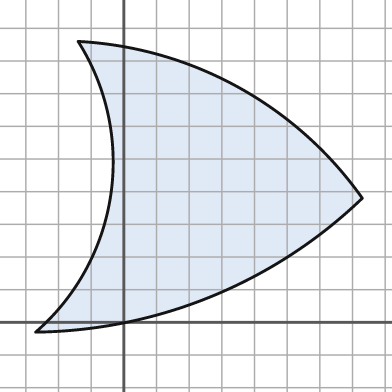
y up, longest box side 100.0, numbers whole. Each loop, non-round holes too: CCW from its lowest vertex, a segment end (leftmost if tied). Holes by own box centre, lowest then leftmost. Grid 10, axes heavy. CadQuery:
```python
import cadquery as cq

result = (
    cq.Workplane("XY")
    .moveTo(-27.0, -3.0)
    .threePointArc((27.0, 8.0), (73.0, 38.0))
    .threePointArc((35.0, 72.0), (-14.0, 86.0))
    .threePointArc((-4.0, 39.0), (-27.0, -3.0))
    .close()
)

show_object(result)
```